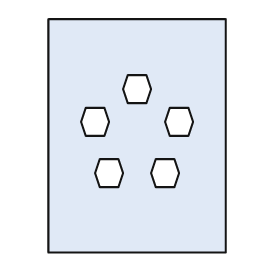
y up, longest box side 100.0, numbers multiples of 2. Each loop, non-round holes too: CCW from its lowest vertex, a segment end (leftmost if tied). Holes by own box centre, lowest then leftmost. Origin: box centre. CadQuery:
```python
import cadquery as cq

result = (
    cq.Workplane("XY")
    .moveTo(-38.0, -50.0)
    .lineTo(38.0, -50.0)
    .lineTo(38.0, 50.0)
    .lineTo(-38.0, 50.0)
    .close()
    .moveTo(-16.0, -22.0)
    .lineTo(-8.0, -22.0)
    .lineTo(-6.0, -16.0)
    .lineTo(-8.0, -10.0)
    .lineTo(-16.0, -10.0)
    .lineTo(-18.0, -16.0)
    .close()
    .moveTo(8.0, -22.0)
    .lineTo(16.0, -22.0)
    .lineTo(18.0, -16.0)
    .lineTo(16.0, -10.0)
    .lineTo(8.0, -10.0)
    .lineTo(6.0, -16.0)
    .close()
    .moveTo(-22.0, 0.0)
    .lineTo(-14.0, 0.0)
    .lineTo(-12.0, 6.0)
    .lineTo(-14.0, 12.0)
    .lineTo(-22.0, 12.0)
    .lineTo(-24.0, 6.0)
    .close()
    .moveTo(14.0, 0.0)
    .lineTo(22.0, 0.0)
    .lineTo(24.0, 6.0)
    .lineTo(22.0, 12.0)
    .lineTo(14.0, 12.0)
    .lineTo(12.0, 6.0)
    .close()
    .moveTo(-4.0, 14.0)
    .lineTo(4.0, 14.0)
    .lineTo(6.0, 20.0)
    .lineTo(4.0, 26.0)
    .lineTo(-4.0, 26.0)
    .lineTo(-6.0, 20.0)
    .close()
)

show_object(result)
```